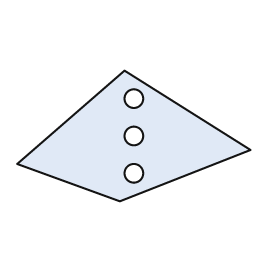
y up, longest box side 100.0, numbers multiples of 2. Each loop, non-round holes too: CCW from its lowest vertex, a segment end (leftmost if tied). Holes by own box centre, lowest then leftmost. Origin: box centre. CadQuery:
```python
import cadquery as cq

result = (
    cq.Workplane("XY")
    .moveTo(-6.0, -28.0)
    .lineTo(50.0, -6.0)
    .lineTo(-4.0, 28.0)
    .lineTo(-50.0, -12.0)
    .close()
    .moveTo(0.0, -16.0)
    .circle(4.0)
    .moveTo(0.0, 0.0)
    .circle(4.0)
    .moveTo(0.0, 16.0)
    .circle(4.0)
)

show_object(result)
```